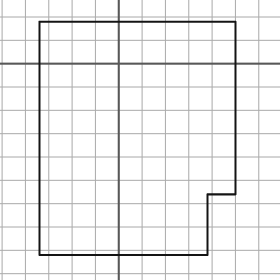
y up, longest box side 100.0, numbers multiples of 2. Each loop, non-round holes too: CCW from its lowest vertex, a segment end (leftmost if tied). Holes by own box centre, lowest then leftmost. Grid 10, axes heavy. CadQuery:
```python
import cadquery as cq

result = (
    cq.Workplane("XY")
    .moveTo(-34.0, -82.0)
    .lineTo(38.0, -82.0)
    .lineTo(38.0, -56.0)
    .lineTo(50.0, -56.0)
    .lineTo(50.0, 18.0)
    .lineTo(-34.0, 18.0)
    .close()
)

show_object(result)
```